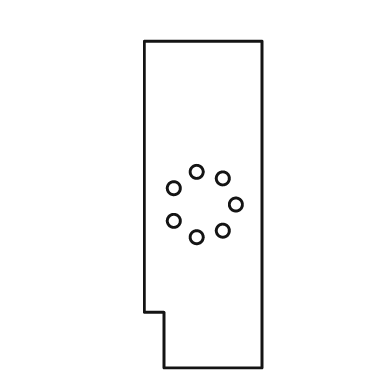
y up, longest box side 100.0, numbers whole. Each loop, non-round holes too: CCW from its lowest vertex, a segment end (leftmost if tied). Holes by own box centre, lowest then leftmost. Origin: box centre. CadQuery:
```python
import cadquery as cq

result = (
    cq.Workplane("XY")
    .moveTo(-12.0, -50.0)
    .lineTo(18.0, -50.0)
    .lineTo(18.0, 50.0)
    .lineTo(-18.0, 50.0)
    .lineTo(-18.0, -33.0)
    .lineTo(-12.0, -33.0)
    .close()
    .moveTo(-2.0, -10.0)
    .circle(2.0)
    .moveTo(6.0, -8.0)
    .circle(2.0)
    .moveTo(-9.0, -5.0)
    .circle(2.0)
    .moveTo(10.0, 0.0)
    .circle(2.0)
    .moveTo(-9.0, 5.0)
    .circle(2.0)
    .moveTo(6.0, 8.0)
    .circle(2.0)
    .moveTo(-2.0, 10.0)
    .circle(2.0)
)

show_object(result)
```